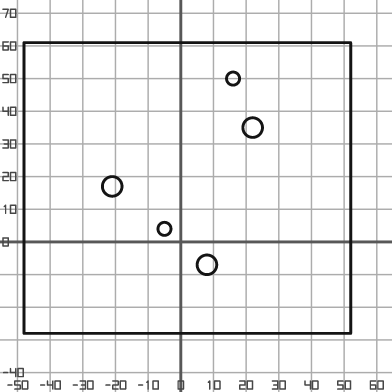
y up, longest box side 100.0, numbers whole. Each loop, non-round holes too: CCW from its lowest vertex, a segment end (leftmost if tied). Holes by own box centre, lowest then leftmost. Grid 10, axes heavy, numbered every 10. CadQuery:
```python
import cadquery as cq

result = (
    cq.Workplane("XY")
    .moveTo(-48.0, -28.0)
    .lineTo(52.0, -28.0)
    .lineTo(52.0, 61.0)
    .lineTo(-48.0, 61.0)
    .close()
    .moveTo(8.0, -7.0)
    .circle(3.0)
    .moveTo(-5.0, 4.0)
    .circle(2.0)
    .moveTo(-21.0, 17.0)
    .circle(3.0)
    .moveTo(22.0, 35.0)
    .circle(3.0)
    .moveTo(16.0, 50.0)
    .circle(2.0)
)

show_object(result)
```